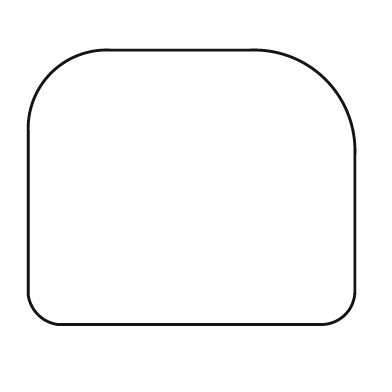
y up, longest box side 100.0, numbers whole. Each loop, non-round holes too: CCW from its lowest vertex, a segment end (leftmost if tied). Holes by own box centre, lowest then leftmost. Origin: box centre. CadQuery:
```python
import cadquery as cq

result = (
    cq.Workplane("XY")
    .moveTo(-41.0, -42.0)
    .lineTo(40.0, -42.0)
    .threePointArc((47.0, -39.0), (50.0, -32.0))
    .lineTo(50.0, 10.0)
    .threePointArc((41.0, 33.0), (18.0, 42.0))
    .lineTo(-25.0, 42.0)
    .threePointArc((-43.0, 35.0), (-50.0, 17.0))
    .lineTo(-50.0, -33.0)
    .threePointArc((-47.0, -39.0), (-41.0, -42.0))
    .close()
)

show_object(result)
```